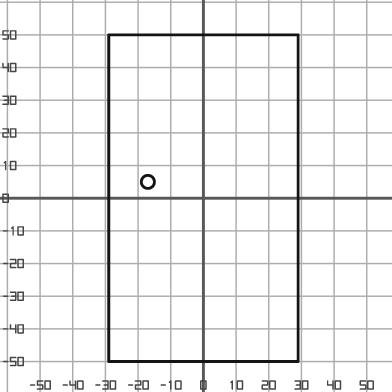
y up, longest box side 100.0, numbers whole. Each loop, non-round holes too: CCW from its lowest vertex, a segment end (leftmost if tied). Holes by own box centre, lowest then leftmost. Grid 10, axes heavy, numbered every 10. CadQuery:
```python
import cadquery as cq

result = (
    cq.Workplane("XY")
    .moveTo(-29.0, -50.0)
    .lineTo(29.0, -50.0)
    .lineTo(29.0, 50.0)
    .lineTo(-29.0, 50.0)
    .close()
    .moveTo(-17.0, 5.0)
    .circle(2.0)
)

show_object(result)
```